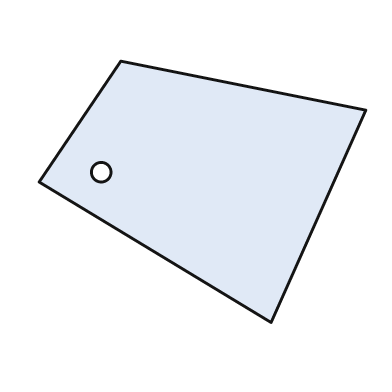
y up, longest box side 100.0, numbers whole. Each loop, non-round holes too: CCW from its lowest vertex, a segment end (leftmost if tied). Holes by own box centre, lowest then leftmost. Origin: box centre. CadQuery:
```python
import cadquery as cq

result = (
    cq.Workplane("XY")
    .moveTo(21.0, -40.0)
    .lineTo(50.0, 25.0)
    .lineTo(-25.0, 40.0)
    .lineTo(-50.0, 3.0)
    .close()
    .moveTo(-31.0, 6.0)
    .circle(3.0)
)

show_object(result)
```